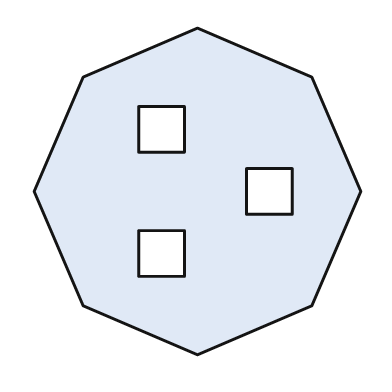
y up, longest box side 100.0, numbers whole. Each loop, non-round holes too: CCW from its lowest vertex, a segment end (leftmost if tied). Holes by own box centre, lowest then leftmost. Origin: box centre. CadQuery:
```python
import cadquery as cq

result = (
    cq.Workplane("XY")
    .moveTo(0.0, -50.0)
    .lineTo(35.0, -35.0)
    .lineTo(50.0, 0.0)
    .lineTo(35.0, 35.0)
    .lineTo(0.0, 50.0)
    .lineTo(-35.0, 35.0)
    .lineTo(-50.0, 0.0)
    .lineTo(-35.0, -35.0)
    .close()
    .moveTo(-18.0, -26.0)
    .lineTo(-4.0, -26.0)
    .lineTo(-4.0, -12.0)
    .lineTo(-18.0, -12.0)
    .close()
    .moveTo(15.0, -7.0)
    .lineTo(29.0, -7.0)
    .lineTo(29.0, 7.0)
    .lineTo(15.0, 7.0)
    .close()
    .moveTo(-18.0, 12.0)
    .lineTo(-4.0, 12.0)
    .lineTo(-4.0, 26.0)
    .lineTo(-18.0, 26.0)
    .close()
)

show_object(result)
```